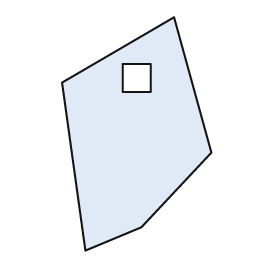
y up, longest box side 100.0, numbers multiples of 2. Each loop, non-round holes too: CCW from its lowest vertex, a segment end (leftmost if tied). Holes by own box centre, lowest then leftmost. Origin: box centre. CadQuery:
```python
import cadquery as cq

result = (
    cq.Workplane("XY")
    .moveTo(-22.0, -50.0)
    .lineTo(2.0, -40.0)
    .lineTo(32.0, -8.0)
    .lineTo(16.0, 50.0)
    .lineTo(-32.0, 22.0)
    .close()
    .moveTo(-6.0, 18.0)
    .lineTo(6.0, 18.0)
    .lineTo(6.0, 30.0)
    .lineTo(-6.0, 30.0)
    .close()
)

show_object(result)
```